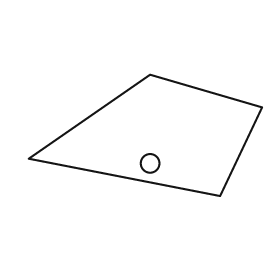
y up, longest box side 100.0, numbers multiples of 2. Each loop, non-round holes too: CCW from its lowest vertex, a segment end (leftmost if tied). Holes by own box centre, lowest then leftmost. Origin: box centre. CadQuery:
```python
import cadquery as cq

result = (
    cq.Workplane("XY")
    .moveTo(32.0, -26.0)
    .lineTo(50.0, 12.0)
    .lineTo(2.0, 26.0)
    .lineTo(-50.0, -10.0)
    .close()
    .moveTo(2.0, -12.0)
    .circle(4.0)
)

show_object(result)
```